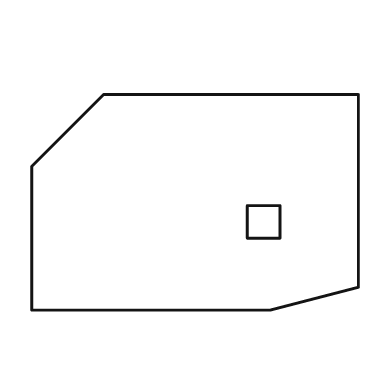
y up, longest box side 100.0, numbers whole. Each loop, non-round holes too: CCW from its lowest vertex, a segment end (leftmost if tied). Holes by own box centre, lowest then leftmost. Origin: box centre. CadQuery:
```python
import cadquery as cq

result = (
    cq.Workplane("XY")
    .moveTo(-50.0, -33.0)
    .lineTo(23.0, -33.0)
    .lineTo(50.0, -26.0)
    .lineTo(50.0, 33.0)
    .lineTo(-28.0, 33.0)
    .lineTo(-50.0, 11.0)
    .close()
    .moveTo(16.0, -11.0)
    .lineTo(26.0, -11.0)
    .lineTo(26.0, -1.0)
    .lineTo(16.0, -1.0)
    .close()
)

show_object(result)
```